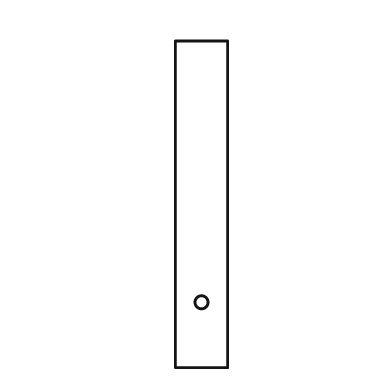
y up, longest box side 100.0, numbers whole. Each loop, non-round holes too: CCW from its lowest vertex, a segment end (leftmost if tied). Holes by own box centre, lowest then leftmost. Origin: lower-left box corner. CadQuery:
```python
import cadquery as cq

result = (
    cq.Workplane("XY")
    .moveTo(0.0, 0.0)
    .lineTo(16.0, 0.0)
    .lineTo(16.0, 100.0)
    .lineTo(0.0, 100.0)
    .close()
    .moveTo(8.0, 20.0)
    .circle(2.0)
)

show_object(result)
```